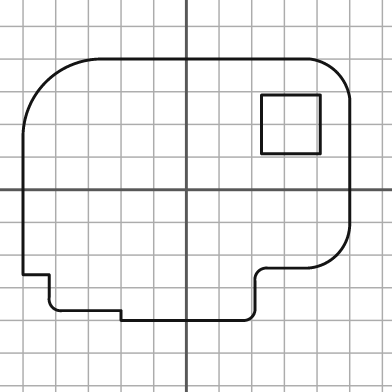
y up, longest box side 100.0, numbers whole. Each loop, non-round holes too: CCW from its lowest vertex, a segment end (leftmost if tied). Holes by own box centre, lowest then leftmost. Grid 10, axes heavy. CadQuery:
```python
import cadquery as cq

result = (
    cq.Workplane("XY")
    .moveTo(-20.0, -40.0)
    .lineTo(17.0, -40.0)
    .threePointArc((20.0, -39.0), (21.0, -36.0))
    .lineTo(21.0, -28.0)
    .threePointArc((22.0, -25.0), (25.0, -24.0))
    .lineTo(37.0, -24.0)
    .threePointArc((46.0, -20.0), (50.0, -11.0))
    .lineTo(50.0, 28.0)
    .threePointArc((46.0, 36.0), (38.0, 40.0))
    .lineTo(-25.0, 40.0)
    .threePointArc((-43.0, 33.0), (-50.0, 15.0))
    .lineTo(-50.0, -26.0)
    .lineTo(-42.0, -26.0)
    .lineTo(-42.0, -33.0)
    .threePointArc((-41.0, -36.0), (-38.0, -37.0))
    .lineTo(-20.0, -37.0)
    .close()
    .moveTo(23.0, 11.0)
    .lineTo(41.0, 11.0)
    .lineTo(41.0, 29.0)
    .lineTo(23.0, 29.0)
    .close()
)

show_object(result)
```